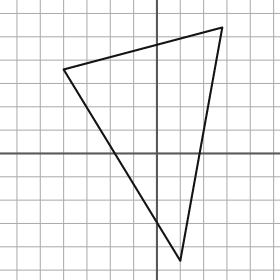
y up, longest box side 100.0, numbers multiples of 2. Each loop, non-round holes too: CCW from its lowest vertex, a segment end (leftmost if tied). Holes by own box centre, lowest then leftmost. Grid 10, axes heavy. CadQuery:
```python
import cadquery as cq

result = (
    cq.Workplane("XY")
    .moveTo(10.0, -46.0)
    .lineTo(28.0, 54.0)
    .lineTo(-40.0, 36.0)
    .close()
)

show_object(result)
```